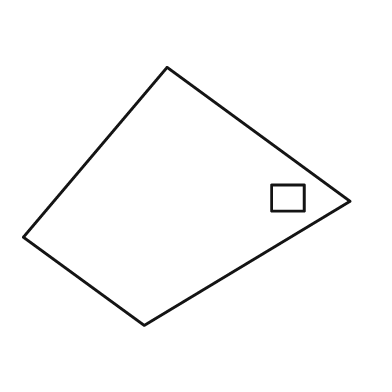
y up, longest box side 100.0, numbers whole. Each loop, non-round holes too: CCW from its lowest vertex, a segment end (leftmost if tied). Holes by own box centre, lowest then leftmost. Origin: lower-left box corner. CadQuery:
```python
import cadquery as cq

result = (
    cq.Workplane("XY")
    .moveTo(37.0, 0.0)
    .lineTo(100.0, 38.0)
    .lineTo(44.0, 79.0)
    .lineTo(0.0, 27.0)
    .close()
    .moveTo(76.0, 35.0)
    .lineTo(86.0, 35.0)
    .lineTo(86.0, 43.0)
    .lineTo(76.0, 43.0)
    .close()
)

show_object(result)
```